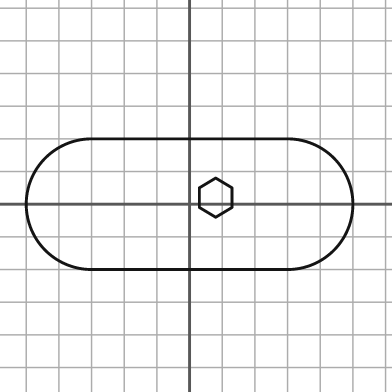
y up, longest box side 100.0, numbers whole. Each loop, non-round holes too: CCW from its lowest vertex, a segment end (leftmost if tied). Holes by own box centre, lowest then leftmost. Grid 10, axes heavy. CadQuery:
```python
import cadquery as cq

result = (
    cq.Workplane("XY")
    .moveTo(-30.0, -20.0)
    .lineTo(30.0, -20.0)
    .threePointArc((50.0, 0.0), (30.0, 20.0))
    .lineTo(-30.0, 20.0)
    .threePointArc((-50.0, 0.0), (-30.0, -20.0))
    .close()
    .moveTo(8.0, -4.0)
    .lineTo(13.0, -1.0)
    .lineTo(13.0, 5.0)
    .lineTo(8.0, 8.0)
    .lineTo(3.0, 5.0)
    .lineTo(3.0, -1.0)
    .close()
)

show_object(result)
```